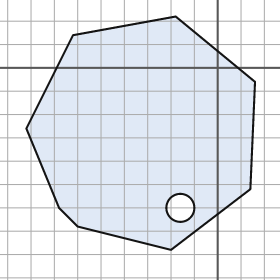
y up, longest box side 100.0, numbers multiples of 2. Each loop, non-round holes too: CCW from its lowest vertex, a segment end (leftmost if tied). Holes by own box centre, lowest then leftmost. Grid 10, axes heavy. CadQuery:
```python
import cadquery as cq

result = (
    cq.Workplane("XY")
    .moveTo(-20.0, -78.0)
    .lineTo(14.0, -52.0)
    .lineTo(16.0, -6.0)
    .lineTo(-18.0, 22.0)
    .lineTo(-62.0, 14.0)
    .lineTo(-82.0, -26.0)
    .lineTo(-68.0, -60.0)
    .lineTo(-60.0, -68.0)
    .close()
    .moveTo(-16.0, -60.0)
    .circle(6.0)
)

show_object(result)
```